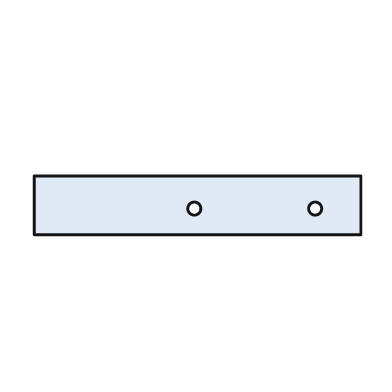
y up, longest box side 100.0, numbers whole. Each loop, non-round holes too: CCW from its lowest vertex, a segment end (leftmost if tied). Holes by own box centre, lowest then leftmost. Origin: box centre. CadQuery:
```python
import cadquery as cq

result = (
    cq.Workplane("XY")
    .moveTo(-50.0, -9.0)
    .lineTo(50.0, -9.0)
    .lineTo(50.0, 9.0)
    .lineTo(-50.0, 9.0)
    .close()
    .moveTo(-1.0, -1.0)
    .circle(2.0)
    .moveTo(36.0, -1.0)
    .circle(2.0)
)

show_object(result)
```